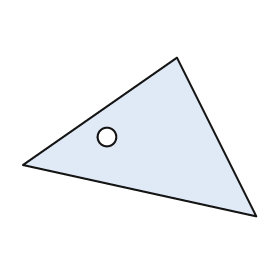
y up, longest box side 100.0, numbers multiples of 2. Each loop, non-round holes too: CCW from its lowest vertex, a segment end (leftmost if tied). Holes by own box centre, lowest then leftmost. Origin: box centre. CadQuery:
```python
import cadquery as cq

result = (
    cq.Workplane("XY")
    .moveTo(50.0, -34.0)
    .lineTo(16.0, 34.0)
    .lineTo(-50.0, -12.0)
    .close()
    .moveTo(-14.0, 0.0)
    .circle(4.0)
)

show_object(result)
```